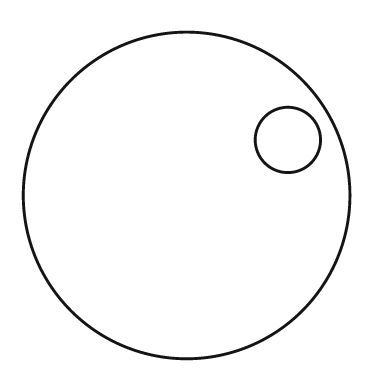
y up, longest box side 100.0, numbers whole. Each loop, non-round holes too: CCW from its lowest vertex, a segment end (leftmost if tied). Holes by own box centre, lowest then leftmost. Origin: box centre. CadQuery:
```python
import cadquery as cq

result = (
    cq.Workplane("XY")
    .moveTo(0.0, 0.0)
    .circle(50.0)
    .moveTo(31.0, 17.0)
    .circle(10.0)
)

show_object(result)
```